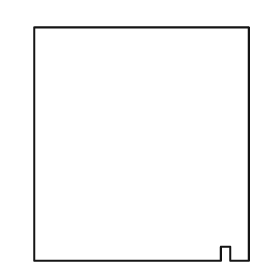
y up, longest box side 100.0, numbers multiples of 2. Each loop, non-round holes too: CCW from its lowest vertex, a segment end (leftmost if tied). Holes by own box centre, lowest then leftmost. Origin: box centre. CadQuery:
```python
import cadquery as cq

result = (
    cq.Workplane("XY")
    .moveTo(-46.0, -50.0)
    .lineTo(34.0, -50.0)
    .lineTo(34.0, -44.0)
    .lineTo(38.0, -44.0)
    .lineTo(38.0, -50.0)
    .lineTo(46.0, -50.0)
    .lineTo(46.0, 50.0)
    .lineTo(-46.0, 50.0)
    .close()
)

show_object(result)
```